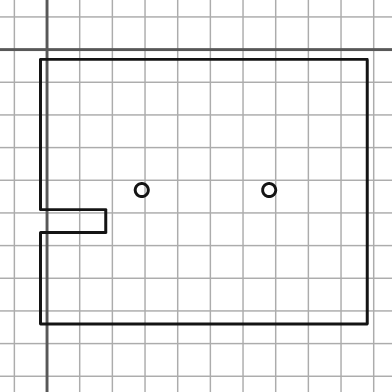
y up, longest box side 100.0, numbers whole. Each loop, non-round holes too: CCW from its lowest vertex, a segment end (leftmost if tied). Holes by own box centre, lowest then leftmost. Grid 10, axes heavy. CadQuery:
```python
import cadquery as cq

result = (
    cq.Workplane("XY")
    .moveTo(-2.0, -84.0)
    .lineTo(98.0, -84.0)
    .lineTo(98.0, -3.0)
    .lineTo(-2.0, -3.0)
    .lineTo(-2.0, -49.0)
    .lineTo(18.0, -49.0)
    .lineTo(18.0, -56.0)
    .lineTo(-2.0, -56.0)
    .close()
    .moveTo(29.0, -43.0)
    .circle(2.0)
    .moveTo(68.0, -43.0)
    .circle(2.0)
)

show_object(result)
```